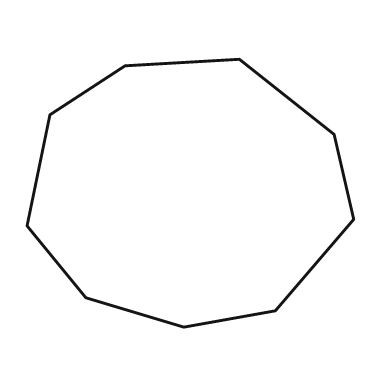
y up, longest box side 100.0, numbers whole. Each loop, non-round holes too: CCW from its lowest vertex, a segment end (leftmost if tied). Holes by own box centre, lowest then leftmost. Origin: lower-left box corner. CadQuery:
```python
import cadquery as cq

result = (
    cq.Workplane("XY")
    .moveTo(48.0, 0.0)
    .lineTo(76.0, 5.0)
    .lineTo(100.0, 33.0)
    .lineTo(94.0, 59.0)
    .lineTo(65.0, 82.0)
    .lineTo(30.0, 80.0)
    .lineTo(7.0, 65.0)
    .lineTo(0.0, 31.0)
    .lineTo(18.0, 9.0)
    .close()
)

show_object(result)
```